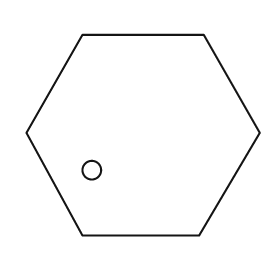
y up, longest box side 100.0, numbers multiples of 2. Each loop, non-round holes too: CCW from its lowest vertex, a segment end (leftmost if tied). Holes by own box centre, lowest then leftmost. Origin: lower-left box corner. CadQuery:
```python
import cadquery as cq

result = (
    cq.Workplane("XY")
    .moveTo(24.0, 0.0)
    .lineTo(74.0, 0.0)
    .lineTo(100.0, 44.0)
    .lineTo(76.0, 86.0)
    .lineTo(24.0, 86.0)
    .lineTo(0.0, 44.0)
    .close()
    .moveTo(28.0, 28.0)
    .circle(4.0)
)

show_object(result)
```